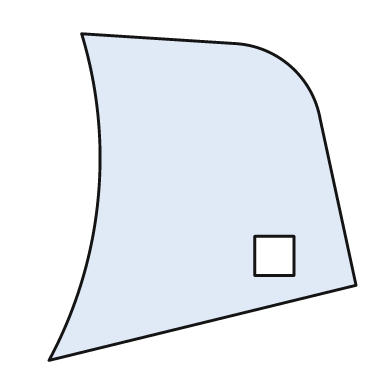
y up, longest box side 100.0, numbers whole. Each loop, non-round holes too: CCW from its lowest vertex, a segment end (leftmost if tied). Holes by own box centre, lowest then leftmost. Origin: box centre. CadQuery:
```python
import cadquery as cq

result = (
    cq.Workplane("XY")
    .moveTo(-47.0, -50.0)
    .lineTo(47.0, -27.0)
    .lineTo(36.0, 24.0)
    .threePointArc((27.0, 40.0), (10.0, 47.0))
    .lineTo(-37.0, 50.0)
    .threePointArc((-32.0, -1.0), (-47.0, -50.0))
    .close()
    .moveTo(16.0, -24.0)
    .lineTo(28.0, -24.0)
    .lineTo(28.0, -12.0)
    .lineTo(16.0, -12.0)
    .close()
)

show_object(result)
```